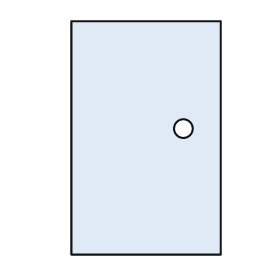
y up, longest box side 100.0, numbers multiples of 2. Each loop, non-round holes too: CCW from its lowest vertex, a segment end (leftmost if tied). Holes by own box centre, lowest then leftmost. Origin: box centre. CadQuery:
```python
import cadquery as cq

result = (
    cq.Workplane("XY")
    .moveTo(-32.0, -50.0)
    .lineTo(32.0, -50.0)
    .lineTo(32.0, 50.0)
    .lineTo(-32.0, 50.0)
    .close()
    .moveTo(16.0, 4.0)
    .circle(4.0)
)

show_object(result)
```